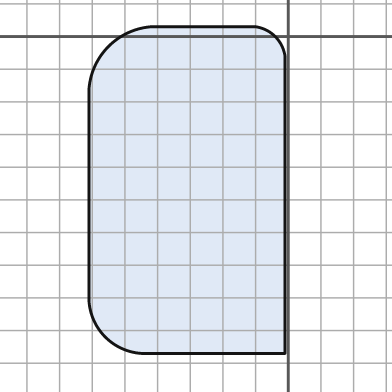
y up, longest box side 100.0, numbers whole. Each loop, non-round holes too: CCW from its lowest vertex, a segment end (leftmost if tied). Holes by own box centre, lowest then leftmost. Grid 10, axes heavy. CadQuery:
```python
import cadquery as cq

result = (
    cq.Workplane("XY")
    .moveTo(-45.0, -97.0)
    .lineTo(-1.0, -97.0)
    .lineTo(-1.0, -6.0)
    .threePointArc((-4.0, 0.0), (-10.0, 3.0))
    .lineTo(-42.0, 3.0)
    .threePointArc((-55.0, -3.0), (-61.0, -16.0))
    .lineTo(-61.0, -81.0)
    .threePointArc((-56.0, -92.0), (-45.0, -97.0))
    .close()
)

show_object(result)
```